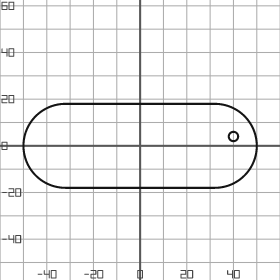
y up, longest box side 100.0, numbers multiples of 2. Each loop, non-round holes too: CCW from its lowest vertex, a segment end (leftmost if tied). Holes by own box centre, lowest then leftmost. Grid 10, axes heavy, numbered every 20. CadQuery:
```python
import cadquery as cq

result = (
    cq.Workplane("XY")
    .moveTo(-32.0, -18.0)
    .lineTo(32.0, -18.0)
    .threePointArc((50.0, 0.0), (32.0, 18.0))
    .lineTo(-32.0, 18.0)
    .threePointArc((-50.0, 0.0), (-32.0, -18.0))
    .close()
    .moveTo(40.0, 4.0)
    .circle(2.0)
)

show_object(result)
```